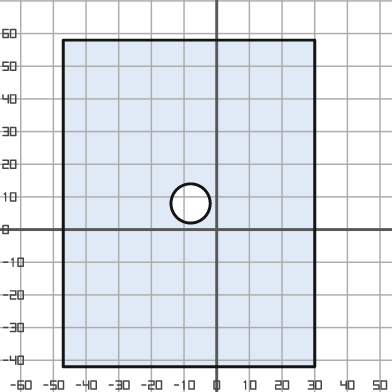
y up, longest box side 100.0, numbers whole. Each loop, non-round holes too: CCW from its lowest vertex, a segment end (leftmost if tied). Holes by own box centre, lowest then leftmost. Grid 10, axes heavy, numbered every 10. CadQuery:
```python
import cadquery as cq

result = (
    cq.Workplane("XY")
    .moveTo(-47.0, -42.0)
    .lineTo(30.0, -42.0)
    .lineTo(30.0, 58.0)
    .lineTo(-47.0, 58.0)
    .close()
    .moveTo(-8.0, 8.0)
    .circle(6.0)
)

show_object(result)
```